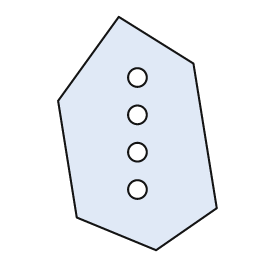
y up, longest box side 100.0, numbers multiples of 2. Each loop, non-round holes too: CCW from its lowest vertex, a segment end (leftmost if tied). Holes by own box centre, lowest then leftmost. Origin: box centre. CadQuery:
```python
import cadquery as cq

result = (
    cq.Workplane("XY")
    .moveTo(8.0, -50.0)
    .lineTo(34.0, -32.0)
    .lineTo(24.0, 30.0)
    .lineTo(-8.0, 50.0)
    .lineTo(-34.0, 14.0)
    .lineTo(-26.0, -36.0)
    .close()
    .moveTo(0.0, -24.0)
    .circle(4.0)
    .moveTo(0.0, -8.0)
    .circle(4.0)
    .moveTo(0.0, 8.0)
    .circle(4.0)
    .moveTo(0.0, 24.0)
    .circle(4.0)
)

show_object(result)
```